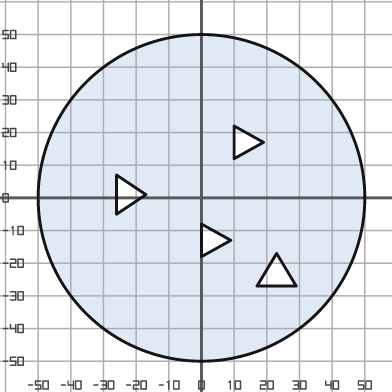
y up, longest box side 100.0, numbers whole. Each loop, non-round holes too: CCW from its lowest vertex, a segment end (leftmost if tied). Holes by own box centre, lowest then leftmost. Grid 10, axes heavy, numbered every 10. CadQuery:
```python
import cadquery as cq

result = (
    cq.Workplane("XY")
    .moveTo(0.0, 0.0)
    .circle(50.0)
    .moveTo(17.0, -27.0)
    .lineTo(29.0, -27.0)
    .lineTo(23.0, -17.0)
    .close()
    .moveTo(0.0, -18.0)
    .lineTo(9.0, -13.0)
    .lineTo(0.0, -8.0)
    .close()
    .moveTo(-26.0, -5.0)
    .lineTo(-17.0, 1.0)
    .lineTo(-26.0, 7.0)
    .close()
    .moveTo(10.0, 12.0)
    .lineTo(19.0, 17.0)
    .lineTo(10.0, 22.0)
    .close()
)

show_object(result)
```